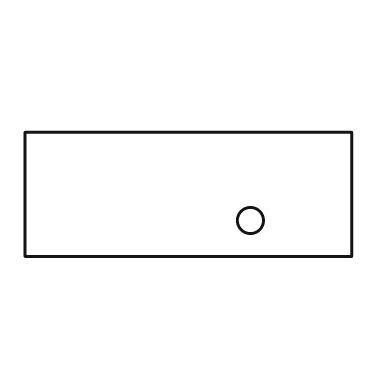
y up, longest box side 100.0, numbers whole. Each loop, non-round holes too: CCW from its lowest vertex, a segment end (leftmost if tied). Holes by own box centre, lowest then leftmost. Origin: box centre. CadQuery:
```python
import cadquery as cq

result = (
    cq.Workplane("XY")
    .moveTo(-50.0, -19.0)
    .lineTo(50.0, -19.0)
    .lineTo(50.0, 19.0)
    .lineTo(-50.0, 19.0)
    .close()
    .moveTo(19.0, -8.0)
    .circle(4.0)
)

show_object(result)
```